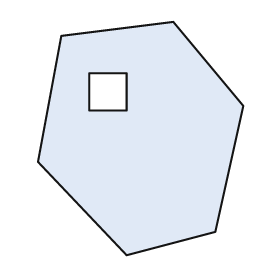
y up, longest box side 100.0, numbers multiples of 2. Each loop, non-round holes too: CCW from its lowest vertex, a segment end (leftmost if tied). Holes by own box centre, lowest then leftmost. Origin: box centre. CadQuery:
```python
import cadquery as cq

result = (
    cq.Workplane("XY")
    .moveTo(-6.0, -50.0)
    .lineTo(32.0, -40.0)
    .lineTo(44.0, 14.0)
    .lineTo(14.0, 50.0)
    .lineTo(-34.0, 44.0)
    .lineTo(-44.0, -10.0)
    .close()
    .moveTo(-22.0, 12.0)
    .lineTo(-6.0, 12.0)
    .lineTo(-6.0, 28.0)
    .lineTo(-22.0, 28.0)
    .close()
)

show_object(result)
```